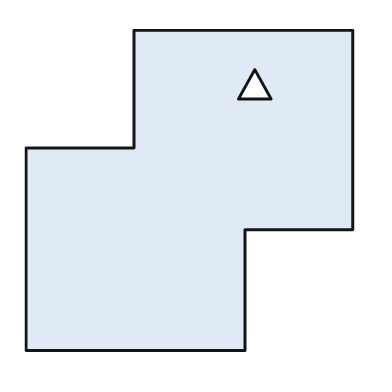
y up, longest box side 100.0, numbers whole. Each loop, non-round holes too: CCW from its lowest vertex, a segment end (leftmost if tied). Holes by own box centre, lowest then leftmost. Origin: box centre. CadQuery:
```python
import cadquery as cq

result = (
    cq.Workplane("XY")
    .moveTo(-50.0, -49.0)
    .lineTo(17.0, -49.0)
    .lineTo(17.0, -12.0)
    .lineTo(50.0, -12.0)
    .lineTo(50.0, 49.0)
    .lineTo(-17.0, 49.0)
    .lineTo(-17.0, 13.0)
    .lineTo(-50.0, 13.0)
    .close()
    .moveTo(15.0, 28.0)
    .lineTo(25.0, 28.0)
    .lineTo(20.0, 37.0)
    .close()
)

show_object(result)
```